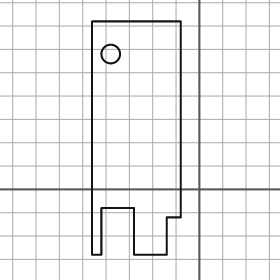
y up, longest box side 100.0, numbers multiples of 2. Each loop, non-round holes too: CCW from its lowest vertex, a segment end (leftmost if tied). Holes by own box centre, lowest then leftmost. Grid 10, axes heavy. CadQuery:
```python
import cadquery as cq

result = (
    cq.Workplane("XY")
    .moveTo(-46.0, -28.0)
    .lineTo(-42.0, -28.0)
    .lineTo(-42.0, -8.0)
    .lineTo(-28.0, -8.0)
    .lineTo(-28.0, -28.0)
    .lineTo(-14.0, -28.0)
    .lineTo(-14.0, -12.0)
    .lineTo(-8.0, -12.0)
    .lineTo(-8.0, 72.0)
    .lineTo(-46.0, 72.0)
    .close()
    .moveTo(-38.0, 58.0)
    .circle(4.0)
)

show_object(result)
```